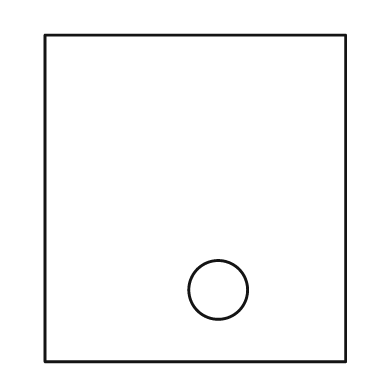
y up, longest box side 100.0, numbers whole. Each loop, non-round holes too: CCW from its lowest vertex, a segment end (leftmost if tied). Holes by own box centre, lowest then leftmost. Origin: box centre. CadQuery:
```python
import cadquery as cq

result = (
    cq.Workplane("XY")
    .moveTo(-46.0, -50.0)
    .lineTo(46.0, -50.0)
    .lineTo(46.0, 50.0)
    .lineTo(-46.0, 50.0)
    .close()
    .moveTo(7.0, -28.0)
    .circle(9.0)
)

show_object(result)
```